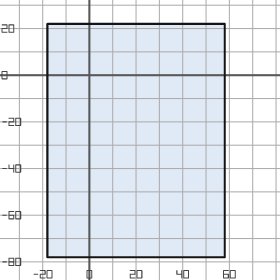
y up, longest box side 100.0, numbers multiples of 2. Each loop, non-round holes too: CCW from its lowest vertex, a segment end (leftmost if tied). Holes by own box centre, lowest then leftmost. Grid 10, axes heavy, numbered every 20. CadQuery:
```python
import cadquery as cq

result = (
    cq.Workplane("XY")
    .moveTo(-18.0, -78.0)
    .lineTo(58.0, -78.0)
    .lineTo(58.0, 22.0)
    .lineTo(-18.0, 22.0)
    .close()
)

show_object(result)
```